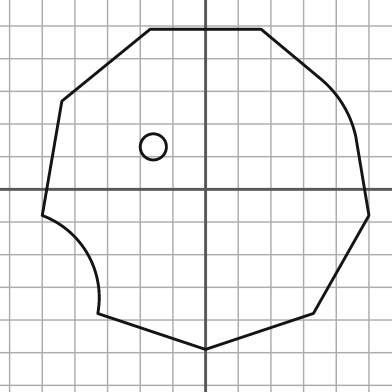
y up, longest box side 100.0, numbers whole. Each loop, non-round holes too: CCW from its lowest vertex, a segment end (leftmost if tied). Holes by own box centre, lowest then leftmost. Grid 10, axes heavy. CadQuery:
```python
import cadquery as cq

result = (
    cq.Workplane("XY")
    .moveTo(0.0, -49.0)
    .lineTo(33.0, -38.0)
    .lineTo(50.0, -8.0)
    .lineTo(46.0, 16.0)
    .threePointArc((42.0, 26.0), (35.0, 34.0))
    .lineTo(17.0, 49.0)
    .lineTo(-17.0, 49.0)
    .lineTo(-44.0, 27.0)
    .lineTo(-50.0, -8.0)
    .threePointArc((-36.0, -20.0), (-33.0, -38.0))
    .close()
    .moveTo(-16.0, 13.0)
    .circle(4.0)
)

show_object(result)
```